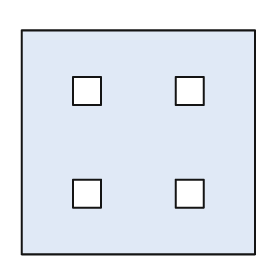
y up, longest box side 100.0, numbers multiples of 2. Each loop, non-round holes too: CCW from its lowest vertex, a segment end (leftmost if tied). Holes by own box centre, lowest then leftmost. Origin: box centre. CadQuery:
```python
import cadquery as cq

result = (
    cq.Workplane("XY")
    .moveTo(-50.0, -48.0)
    .lineTo(50.0, -48.0)
    .lineTo(50.0, 48.0)
    .lineTo(-50.0, 48.0)
    .close()
    .moveTo(-28.0, -28.0)
    .lineTo(-16.0, -28.0)
    .lineTo(-16.0, -16.0)
    .lineTo(-28.0, -16.0)
    .close()
    .moveTo(16.0, -28.0)
    .lineTo(28.0, -28.0)
    .lineTo(28.0, -16.0)
    .lineTo(16.0, -16.0)
    .close()
    .moveTo(-28.0, 16.0)
    .lineTo(-16.0, 16.0)
    .lineTo(-16.0, 28.0)
    .lineTo(-28.0, 28.0)
    .close()
    .moveTo(16.0, 16.0)
    .lineTo(28.0, 16.0)
    .lineTo(28.0, 28.0)
    .lineTo(16.0, 28.0)
    .close()
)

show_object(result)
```